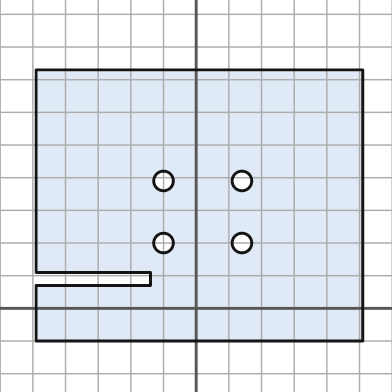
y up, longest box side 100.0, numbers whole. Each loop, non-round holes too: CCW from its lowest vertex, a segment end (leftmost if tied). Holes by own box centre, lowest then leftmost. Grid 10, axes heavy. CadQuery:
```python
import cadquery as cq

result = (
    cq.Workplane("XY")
    .moveTo(-49.0, -10.0)
    .lineTo(51.0, -10.0)
    .lineTo(51.0, 73.0)
    .lineTo(-49.0, 73.0)
    .lineTo(-49.0, 11.0)
    .lineTo(-14.0, 11.0)
    .lineTo(-14.0, 7.0)
    .lineTo(-49.0, 7.0)
    .close()
    .moveTo(-10.0, 20.0)
    .circle(3.0)
    .moveTo(14.0, 20.0)
    .circle(3.0)
    .moveTo(-10.0, 39.0)
    .circle(3.0)
    .moveTo(14.0, 39.0)
    .circle(3.0)
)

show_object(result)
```